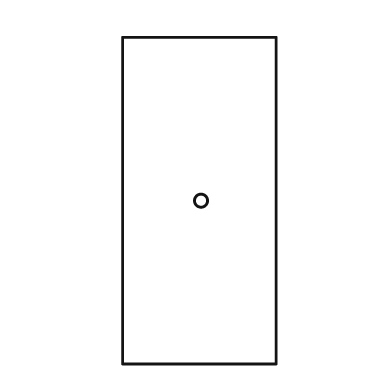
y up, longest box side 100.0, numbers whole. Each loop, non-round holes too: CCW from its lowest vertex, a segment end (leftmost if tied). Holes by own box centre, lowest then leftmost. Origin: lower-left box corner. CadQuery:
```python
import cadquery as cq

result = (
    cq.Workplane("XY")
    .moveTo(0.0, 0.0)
    .lineTo(47.0, 0.0)
    .lineTo(47.0, 100.0)
    .lineTo(0.0, 100.0)
    .close()
    .moveTo(24.0, 50.0)
    .circle(2.0)
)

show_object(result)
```